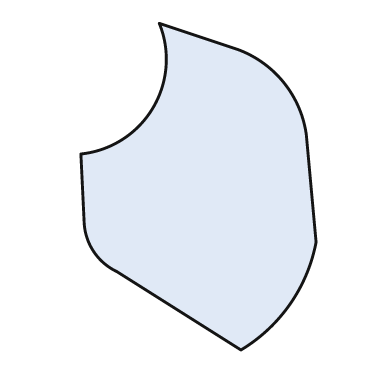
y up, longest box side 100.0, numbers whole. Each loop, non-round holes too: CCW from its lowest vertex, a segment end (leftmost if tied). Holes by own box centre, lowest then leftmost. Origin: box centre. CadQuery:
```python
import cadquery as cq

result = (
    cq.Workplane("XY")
    .moveTo(13.0, -50.0)
    .threePointArc((28.0, -36.0), (36.0, -17.0))
    .lineTo(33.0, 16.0)
    .threePointArc((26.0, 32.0), (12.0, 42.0))
    .lineTo(-12.0, 50.0)
    .threePointArc((-14.0, 24.0), (-36.0, 10.0))
    .lineTo(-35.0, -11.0)
    .threePointArc((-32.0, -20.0), (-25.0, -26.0))
    .close()
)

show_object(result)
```